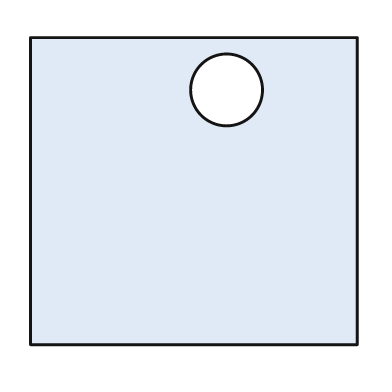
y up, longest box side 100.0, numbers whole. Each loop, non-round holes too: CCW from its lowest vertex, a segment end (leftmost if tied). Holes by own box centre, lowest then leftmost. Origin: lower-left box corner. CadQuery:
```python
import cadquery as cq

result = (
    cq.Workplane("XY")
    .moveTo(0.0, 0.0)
    .lineTo(100.0, 0.0)
    .lineTo(100.0, 94.0)
    .lineTo(0.0, 94.0)
    .close()
    .moveTo(60.0, 78.0)
    .circle(11.0)
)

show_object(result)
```